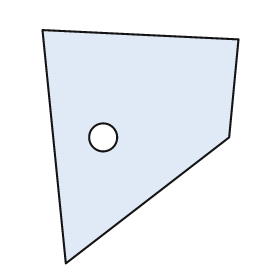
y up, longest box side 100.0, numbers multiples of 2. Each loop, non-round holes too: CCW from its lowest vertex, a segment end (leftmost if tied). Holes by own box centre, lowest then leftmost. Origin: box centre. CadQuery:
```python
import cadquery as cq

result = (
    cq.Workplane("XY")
    .moveTo(-32.0, -50.0)
    .lineTo(38.0, 4.0)
    .lineTo(42.0, 46.0)
    .lineTo(-42.0, 50.0)
    .close()
    .moveTo(-16.0, 4.0)
    .circle(6.0)
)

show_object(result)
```